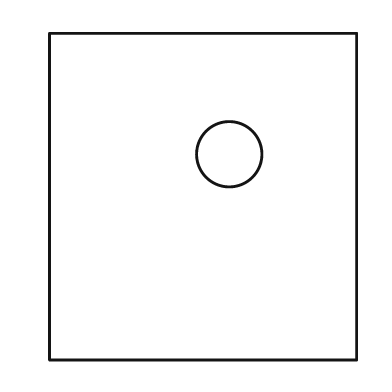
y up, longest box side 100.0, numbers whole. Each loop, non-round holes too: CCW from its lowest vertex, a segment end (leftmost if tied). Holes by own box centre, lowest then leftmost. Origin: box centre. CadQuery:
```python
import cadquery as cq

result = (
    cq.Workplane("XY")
    .moveTo(-47.0, -50.0)
    .lineTo(47.0, -50.0)
    .lineTo(47.0, 50.0)
    .lineTo(-47.0, 50.0)
    .close()
    .moveTo(8.0, 13.0)
    .circle(10.0)
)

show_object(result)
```